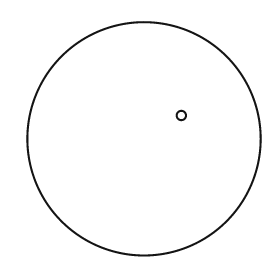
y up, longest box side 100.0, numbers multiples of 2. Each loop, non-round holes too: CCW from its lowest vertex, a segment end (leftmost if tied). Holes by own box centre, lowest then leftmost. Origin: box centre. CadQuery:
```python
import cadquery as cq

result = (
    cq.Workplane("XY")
    .moveTo(0.0, 0.0)
    .circle(50.0)
    .moveTo(16.0, 10.0)
    .circle(2.0)
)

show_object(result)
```